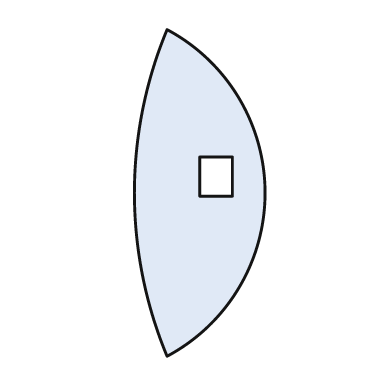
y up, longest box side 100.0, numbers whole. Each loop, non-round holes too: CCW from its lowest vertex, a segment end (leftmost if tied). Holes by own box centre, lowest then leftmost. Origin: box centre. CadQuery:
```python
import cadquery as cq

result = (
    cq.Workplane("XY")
    .moveTo(-10.0, -50.0)
    .threePointArc((20.0, 0.0), (-10.0, 50.0))
    .threePointArc((-20.0, 0.0), (-10.0, -50.0))
    .close()
    .moveTo(0.0, -1.0)
    .lineTo(10.0, -1.0)
    .lineTo(10.0, 11.0)
    .lineTo(0.0, 11.0)
    .close()
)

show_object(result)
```